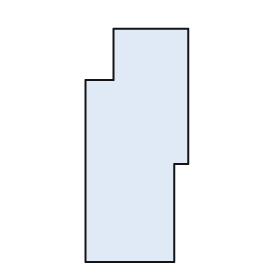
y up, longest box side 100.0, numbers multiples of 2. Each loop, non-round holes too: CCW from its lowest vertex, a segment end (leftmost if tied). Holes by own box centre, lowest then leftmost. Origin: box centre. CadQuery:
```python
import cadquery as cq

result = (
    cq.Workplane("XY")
    .moveTo(-22.0, -50.0)
    .lineTo(16.0, -50.0)
    .lineTo(16.0, -8.0)
    .lineTo(22.0, -8.0)
    .lineTo(22.0, 50.0)
    .lineTo(-10.0, 50.0)
    .lineTo(-10.0, 28.0)
    .lineTo(-22.0, 28.0)
    .close()
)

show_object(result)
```